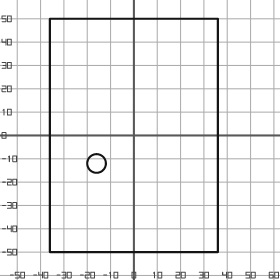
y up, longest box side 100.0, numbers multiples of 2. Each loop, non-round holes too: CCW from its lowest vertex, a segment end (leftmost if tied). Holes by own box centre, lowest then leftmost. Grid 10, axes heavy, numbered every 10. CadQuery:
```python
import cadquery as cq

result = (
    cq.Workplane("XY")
    .moveTo(-36.0, -50.0)
    .lineTo(36.0, -50.0)
    .lineTo(36.0, 50.0)
    .lineTo(-36.0, 50.0)
    .close()
    .moveTo(-16.0, -12.0)
    .circle(4.0)
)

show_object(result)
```